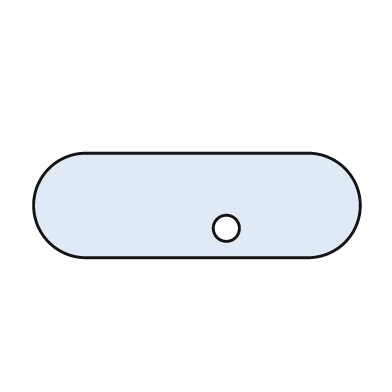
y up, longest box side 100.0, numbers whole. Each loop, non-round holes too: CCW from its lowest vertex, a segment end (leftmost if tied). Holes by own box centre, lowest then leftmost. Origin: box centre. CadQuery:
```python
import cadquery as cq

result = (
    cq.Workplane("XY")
    .moveTo(-34.0, -16.0)
    .lineTo(34.0, -16.0)
    .threePointArc((50.0, 0.0), (34.0, 16.0))
    .lineTo(-34.0, 16.0)
    .threePointArc((-50.0, 0.0), (-34.0, -16.0))
    .close()
    .moveTo(9.0, -7.0)
    .circle(4.0)
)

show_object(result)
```